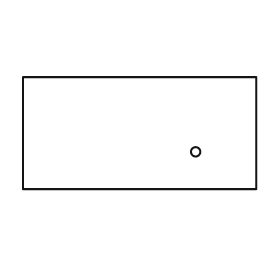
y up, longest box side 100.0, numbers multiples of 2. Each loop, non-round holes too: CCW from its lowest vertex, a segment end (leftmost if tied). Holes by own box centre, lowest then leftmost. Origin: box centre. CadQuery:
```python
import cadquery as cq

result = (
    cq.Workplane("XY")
    .moveTo(-50.0, -24.0)
    .lineTo(50.0, -24.0)
    .lineTo(50.0, 24.0)
    .lineTo(-50.0, 24.0)
    .close()
    .moveTo(24.0, -8.0)
    .circle(2.0)
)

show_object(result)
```